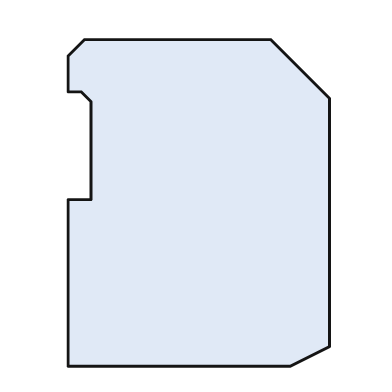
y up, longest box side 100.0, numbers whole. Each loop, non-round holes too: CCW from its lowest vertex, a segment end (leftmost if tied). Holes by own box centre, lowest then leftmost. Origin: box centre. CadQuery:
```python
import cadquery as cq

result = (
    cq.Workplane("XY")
    .moveTo(-40.0, -50.0)
    .lineTo(28.0, -50.0)
    .lineTo(40.0, -44.0)
    .lineTo(40.0, 32.0)
    .lineTo(22.0, 50.0)
    .lineTo(-35.0, 50.0)
    .lineTo(-40.0, 45.0)
    .lineTo(-40.0, 34.0)
    .lineTo(-36.0, 34.0)
    .lineTo(-33.0, 31.0)
    .lineTo(-33.0, 1.0)
    .lineTo(-40.0, 1.0)
    .close()
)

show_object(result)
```